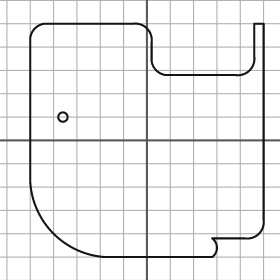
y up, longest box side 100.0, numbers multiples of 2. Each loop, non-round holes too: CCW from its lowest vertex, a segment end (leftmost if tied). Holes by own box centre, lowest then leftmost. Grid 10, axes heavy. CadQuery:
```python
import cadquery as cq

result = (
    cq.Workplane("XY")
    .moveTo(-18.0, -50.0)
    .lineTo(28.0, -50.0)
    .threePointArc((30.0, -46.0), (28.0, -42.0))
    .lineTo(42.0, -42.0)
    .threePointArc((48.0, -40.0), (50.0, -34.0))
    .lineTo(50.0, 50.0)
    .lineTo(46.0, 50.0)
    .lineTo(46.0, 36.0)
    .threePointArc((44.0, 30.0), (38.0, 28.0))
    .lineTo(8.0, 28.0)
    .threePointArc((4.0, 30.0), (2.0, 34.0))
    .lineTo(2.0, 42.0)
    .threePointArc((0.0, 48.0), (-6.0, 50.0))
    .lineTo(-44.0, 50.0)
    .threePointArc((-48.0, 48.0), (-50.0, 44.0))
    .lineTo(-50.0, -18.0)
    .threePointArc((-40.0, -40.0), (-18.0, -50.0))
    .close()
    .moveTo(-36.0, 10.0)
    .circle(2.0)
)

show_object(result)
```